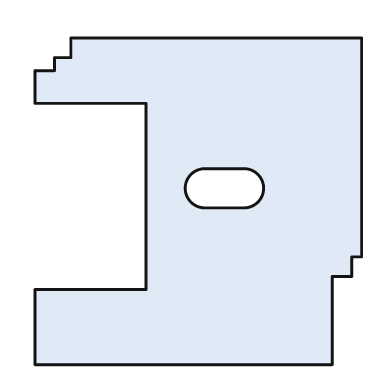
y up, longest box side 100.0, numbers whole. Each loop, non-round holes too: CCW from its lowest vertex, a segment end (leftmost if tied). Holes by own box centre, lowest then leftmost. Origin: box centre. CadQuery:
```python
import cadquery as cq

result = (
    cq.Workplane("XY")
    .moveTo(-50.0, -50.0)
    .lineTo(41.0, -50.0)
    .lineTo(41.0, -23.0)
    .lineTo(47.0, -23.0)
    .lineTo(47.0, -17.0)
    .lineTo(50.0, -17.0)
    .lineTo(50.0, 50.0)
    .lineTo(-39.0, 50.0)
    .lineTo(-39.0, 44.0)
    .lineTo(-44.0, 44.0)
    .lineTo(-44.0, 40.0)
    .lineTo(-50.0, 40.0)
    .lineTo(-50.0, 30.0)
    .lineTo(-16.0, 30.0)
    .lineTo(-16.0, -27.0)
    .lineTo(-50.0, -27.0)
    .close()
    .moveTo(2.0, -2.0)
    .lineTo(14.0, -2.0)
    .threePointArc((20.0, 4.0), (14.0, 10.0))
    .lineTo(2.0, 10.0)
    .threePointArc((-4.0, 4.0), (2.0, -2.0))
    .close()
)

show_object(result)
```